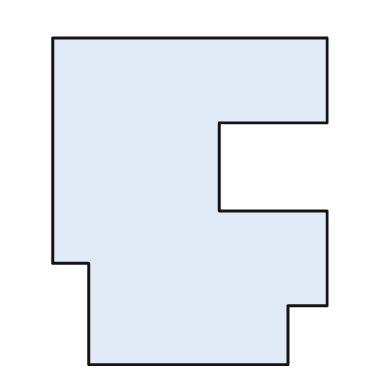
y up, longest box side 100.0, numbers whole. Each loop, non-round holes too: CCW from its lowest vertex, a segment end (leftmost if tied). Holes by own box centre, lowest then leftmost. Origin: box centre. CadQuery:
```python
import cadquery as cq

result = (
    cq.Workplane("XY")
    .moveTo(-31.0, -50.0)
    .lineTo(30.0, -50.0)
    .lineTo(30.0, -32.0)
    .lineTo(42.0, -32.0)
    .lineTo(42.0, -3.0)
    .lineTo(9.0, -3.0)
    .lineTo(9.0, 24.0)
    .lineTo(42.0, 24.0)
    .lineTo(42.0, 50.0)
    .lineTo(-42.0, 50.0)
    .lineTo(-42.0, -19.0)
    .lineTo(-31.0, -19.0)
    .close()
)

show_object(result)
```